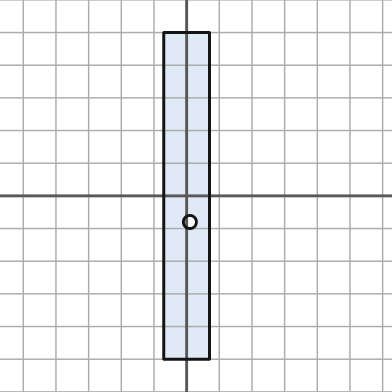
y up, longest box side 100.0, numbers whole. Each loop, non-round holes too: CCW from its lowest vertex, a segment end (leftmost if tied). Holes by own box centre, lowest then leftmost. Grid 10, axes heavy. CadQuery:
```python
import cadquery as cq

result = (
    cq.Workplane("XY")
    .moveTo(-7.0, -50.0)
    .lineTo(7.0, -50.0)
    .lineTo(7.0, 50.0)
    .lineTo(-7.0, 50.0)
    .close()
    .moveTo(1.0, -8.0)
    .circle(2.0)
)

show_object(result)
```